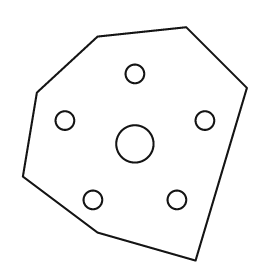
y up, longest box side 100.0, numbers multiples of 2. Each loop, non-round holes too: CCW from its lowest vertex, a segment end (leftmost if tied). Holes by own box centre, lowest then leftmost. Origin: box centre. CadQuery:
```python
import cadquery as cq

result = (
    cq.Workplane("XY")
    .moveTo(26.0, -50.0)
    .lineTo(48.0, 24.0)
    .lineTo(22.0, 50.0)
    .lineTo(-16.0, 46.0)
    .lineTo(-42.0, 22.0)
    .lineTo(-48.0, -14.0)
    .lineTo(-16.0, -38.0)
    .close()
    .moveTo(-18.0, -24.0)
    .circle(4.0)
    .moveTo(18.0, -24.0)
    .circle(4.0)
    .moveTo(0.0, 0.0)
    .circle(8.0)
    .moveTo(-30.0, 10.0)
    .circle(4.0)
    .moveTo(30.0, 10.0)
    .circle(4.0)
    .moveTo(0.0, 30.0)
    .circle(4.0)
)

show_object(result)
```